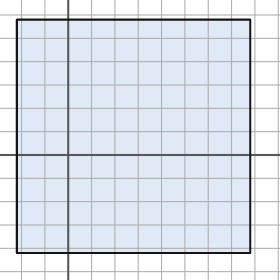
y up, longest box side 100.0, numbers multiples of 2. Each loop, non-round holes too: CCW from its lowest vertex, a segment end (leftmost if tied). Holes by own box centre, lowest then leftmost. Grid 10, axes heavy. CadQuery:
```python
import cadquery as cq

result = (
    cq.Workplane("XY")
    .moveTo(-22.0, -42.0)
    .lineTo(78.0, -42.0)
    .lineTo(78.0, 58.0)
    .lineTo(-22.0, 58.0)
    .close()
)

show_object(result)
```